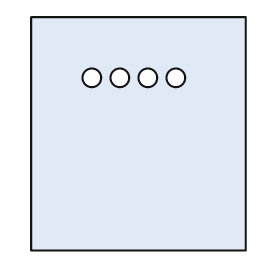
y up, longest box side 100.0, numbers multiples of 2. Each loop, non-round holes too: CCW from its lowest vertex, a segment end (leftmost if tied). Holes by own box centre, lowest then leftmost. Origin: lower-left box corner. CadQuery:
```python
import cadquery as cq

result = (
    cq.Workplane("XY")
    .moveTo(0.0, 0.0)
    .lineTo(92.0, 0.0)
    .lineTo(92.0, 100.0)
    .lineTo(0.0, 100.0)
    .close()
    .moveTo(26.0, 74.0)
    .circle(4.0)
    .moveTo(38.0, 74.0)
    .circle(4.0)
    .moveTo(50.0, 74.0)
    .circle(4.0)
    .moveTo(62.0, 74.0)
    .circle(4.0)
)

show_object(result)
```